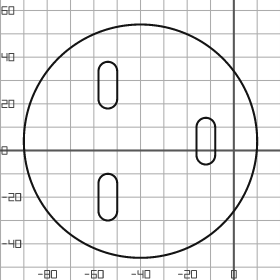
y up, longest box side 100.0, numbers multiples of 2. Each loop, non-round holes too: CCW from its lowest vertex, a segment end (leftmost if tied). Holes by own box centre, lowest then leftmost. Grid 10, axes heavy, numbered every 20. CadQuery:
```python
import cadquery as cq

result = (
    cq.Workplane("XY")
    .moveTo(-40.0, 4.0)
    .circle(50.0)
    .moveTo(-58.0, -26.0)
    .threePointArc((-54.0, -30.0), (-50.0, -26.0))
    .lineTo(-50.0, -14.0)
    .threePointArc((-54.0, -10.0), (-58.0, -14.0))
    .close()
    .moveTo(-16.0, -2.0)
    .threePointArc((-12.0, -6.0), (-8.0, -2.0))
    .lineTo(-8.0, 10.0)
    .threePointArc((-12.0, 14.0), (-16.0, 10.0))
    .close()
    .moveTo(-58.0, 22.0)
    .threePointArc((-54.0, 18.0), (-50.0, 22.0))
    .lineTo(-50.0, 34.0)
    .threePointArc((-54.0, 38.0), (-58.0, 34.0))
    .close()
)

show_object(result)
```